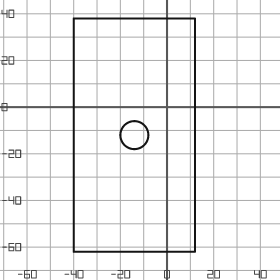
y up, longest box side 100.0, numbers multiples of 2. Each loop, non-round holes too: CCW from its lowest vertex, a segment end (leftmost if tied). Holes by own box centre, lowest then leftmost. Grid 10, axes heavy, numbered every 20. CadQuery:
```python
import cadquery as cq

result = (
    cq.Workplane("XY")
    .moveTo(-40.0, -62.0)
    .lineTo(12.0, -62.0)
    .lineTo(12.0, 38.0)
    .lineTo(-40.0, 38.0)
    .close()
    .moveTo(-14.0, -12.0)
    .circle(6.0)
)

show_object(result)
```